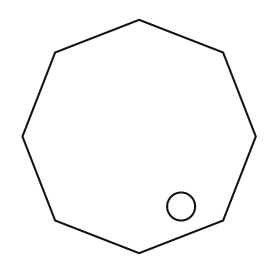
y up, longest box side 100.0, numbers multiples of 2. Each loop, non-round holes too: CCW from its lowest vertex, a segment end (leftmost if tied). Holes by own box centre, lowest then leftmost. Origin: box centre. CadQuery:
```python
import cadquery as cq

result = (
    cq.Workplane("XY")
    .moveTo(0.0, -50.0)
    .lineTo(36.0, -36.0)
    .lineTo(50.0, 0.0)
    .lineTo(36.0, 36.0)
    .lineTo(0.0, 50.0)
    .lineTo(-36.0, 36.0)
    .lineTo(-50.0, 0.0)
    .lineTo(-36.0, -36.0)
    .close()
    .moveTo(18.0, -30.0)
    .circle(6.0)
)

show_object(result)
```